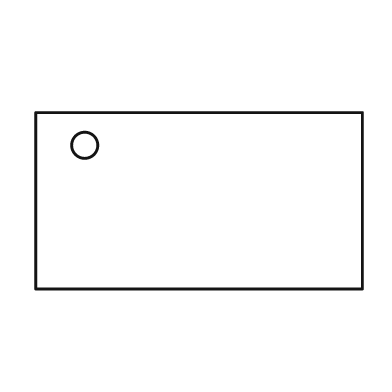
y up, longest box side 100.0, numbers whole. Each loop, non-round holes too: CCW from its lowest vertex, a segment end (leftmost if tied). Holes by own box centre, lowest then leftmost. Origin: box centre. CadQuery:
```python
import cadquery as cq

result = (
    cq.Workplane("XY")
    .moveTo(-50.0, -27.0)
    .lineTo(50.0, -27.0)
    .lineTo(50.0, 27.0)
    .lineTo(-50.0, 27.0)
    .close()
    .moveTo(-35.0, 17.0)
    .circle(4.0)
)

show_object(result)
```